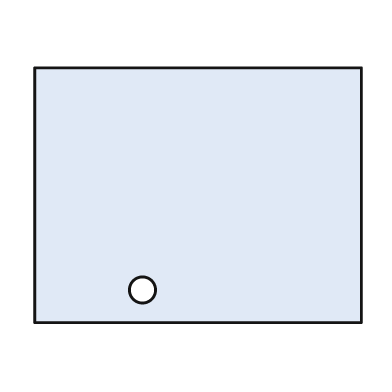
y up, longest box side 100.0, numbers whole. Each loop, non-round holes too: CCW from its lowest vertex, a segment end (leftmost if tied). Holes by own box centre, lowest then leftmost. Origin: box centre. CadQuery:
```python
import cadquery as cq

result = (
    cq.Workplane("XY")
    .moveTo(-50.0, -39.0)
    .lineTo(50.0, -39.0)
    .lineTo(50.0, 39.0)
    .lineTo(-50.0, 39.0)
    .close()
    .moveTo(-17.0, -29.0)
    .circle(4.0)
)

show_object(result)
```